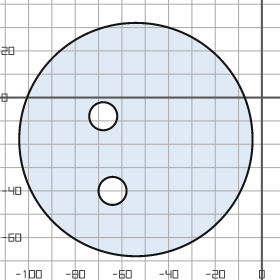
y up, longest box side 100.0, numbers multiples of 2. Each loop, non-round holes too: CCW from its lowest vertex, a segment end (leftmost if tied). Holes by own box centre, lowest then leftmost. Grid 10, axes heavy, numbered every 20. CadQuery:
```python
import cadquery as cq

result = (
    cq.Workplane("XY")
    .moveTo(-54.0, -18.0)
    .circle(50.0)
    .moveTo(-64.0, -40.0)
    .circle(6.0)
    .moveTo(-68.0, -8.0)
    .circle(6.0)
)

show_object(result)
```